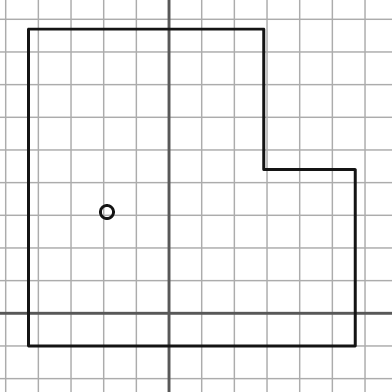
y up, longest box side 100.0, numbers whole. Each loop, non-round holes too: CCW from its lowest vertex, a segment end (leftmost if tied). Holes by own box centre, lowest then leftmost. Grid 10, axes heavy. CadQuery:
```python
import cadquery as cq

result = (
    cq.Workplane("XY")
    .moveTo(-43.0, -10.0)
    .lineTo(57.0, -10.0)
    .lineTo(57.0, 44.0)
    .lineTo(29.0, 44.0)
    .lineTo(29.0, 87.0)
    .lineTo(-43.0, 87.0)
    .close()
    .moveTo(-19.0, 31.0)
    .circle(2.0)
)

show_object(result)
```